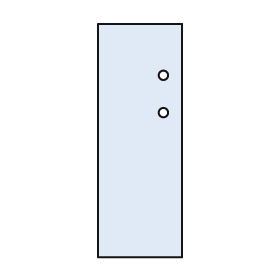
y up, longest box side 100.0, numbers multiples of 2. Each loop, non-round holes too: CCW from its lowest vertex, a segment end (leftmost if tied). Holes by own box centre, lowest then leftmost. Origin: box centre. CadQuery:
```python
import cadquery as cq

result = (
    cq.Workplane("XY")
    .moveTo(-18.0, -50.0)
    .lineTo(18.0, -50.0)
    .lineTo(18.0, 50.0)
    .lineTo(-18.0, 50.0)
    .close()
    .moveTo(10.0, 12.0)
    .circle(2.0)
    .moveTo(10.0, 28.0)
    .circle(2.0)
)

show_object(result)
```